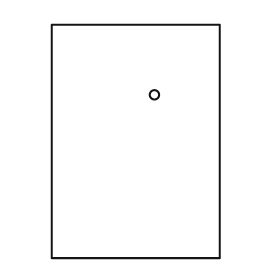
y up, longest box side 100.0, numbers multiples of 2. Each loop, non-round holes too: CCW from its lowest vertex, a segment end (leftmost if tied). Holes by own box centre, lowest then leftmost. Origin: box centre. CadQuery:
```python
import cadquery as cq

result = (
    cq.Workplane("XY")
    .moveTo(-36.0, -50.0)
    .lineTo(36.0, -50.0)
    .lineTo(36.0, 50.0)
    .lineTo(-36.0, 50.0)
    .close()
    .moveTo(8.0, 20.0)
    .circle(2.0)
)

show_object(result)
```